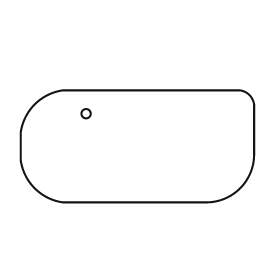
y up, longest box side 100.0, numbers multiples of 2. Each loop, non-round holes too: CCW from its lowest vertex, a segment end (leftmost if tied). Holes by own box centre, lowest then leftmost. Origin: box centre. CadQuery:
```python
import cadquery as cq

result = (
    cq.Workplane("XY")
    .moveTo(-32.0, -24.0)
    .lineTo(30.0, -24.0)
    .threePointArc((44.0, -18.0), (50.0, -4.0))
    .lineTo(50.0, 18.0)
    .threePointArc((48.0, 22.0), (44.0, 24.0))
    .lineTo(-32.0, 24.0)
    .threePointArc((-44.0, 18.0), (-50.0, 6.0))
    .lineTo(-50.0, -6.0)
    .threePointArc((-44.0, -18.0), (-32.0, -24.0))
    .close()
    .moveTo(-22.0, 14.0)
    .circle(2.0)
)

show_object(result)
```